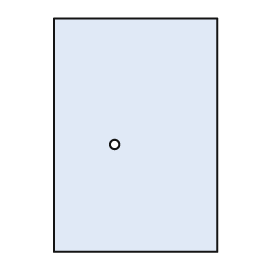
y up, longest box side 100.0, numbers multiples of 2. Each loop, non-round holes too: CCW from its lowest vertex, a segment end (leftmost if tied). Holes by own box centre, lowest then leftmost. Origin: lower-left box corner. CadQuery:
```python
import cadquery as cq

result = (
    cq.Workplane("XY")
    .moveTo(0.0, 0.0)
    .lineTo(70.0, 0.0)
    .lineTo(70.0, 100.0)
    .lineTo(0.0, 100.0)
    .close()
    .moveTo(26.0, 46.0)
    .circle(2.0)
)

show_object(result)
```